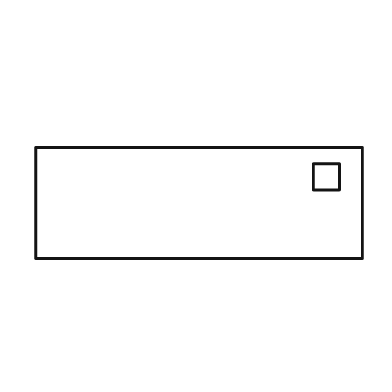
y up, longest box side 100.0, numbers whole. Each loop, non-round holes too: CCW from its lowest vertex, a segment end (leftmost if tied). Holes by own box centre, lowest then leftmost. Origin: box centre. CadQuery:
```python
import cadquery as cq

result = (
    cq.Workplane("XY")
    .moveTo(-50.0, -17.0)
    .lineTo(50.0, -17.0)
    .lineTo(50.0, 17.0)
    .lineTo(-50.0, 17.0)
    .close()
    .moveTo(35.0, 4.0)
    .lineTo(43.0, 4.0)
    .lineTo(43.0, 12.0)
    .lineTo(35.0, 12.0)
    .close()
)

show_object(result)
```